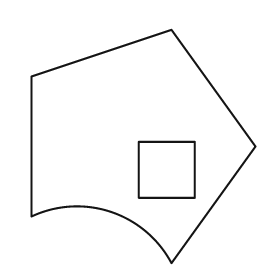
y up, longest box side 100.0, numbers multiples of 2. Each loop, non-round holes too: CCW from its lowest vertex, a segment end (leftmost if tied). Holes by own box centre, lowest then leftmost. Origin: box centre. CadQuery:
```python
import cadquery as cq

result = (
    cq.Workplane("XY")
    .moveTo(12.0, -50.0)
    .lineTo(48.0, 0.0)
    .lineTo(12.0, 50.0)
    .lineTo(-48.0, 30.0)
    .lineTo(-48.0, -30.0)
    .threePointArc((-14.0, -28.0), (12.0, -50.0))
    .close()
    .moveTo(-2.0, -22.0)
    .lineTo(22.0, -22.0)
    .lineTo(22.0, 2.0)
    .lineTo(-2.0, 2.0)
    .close()
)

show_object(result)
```